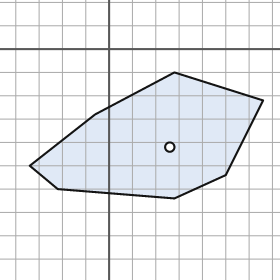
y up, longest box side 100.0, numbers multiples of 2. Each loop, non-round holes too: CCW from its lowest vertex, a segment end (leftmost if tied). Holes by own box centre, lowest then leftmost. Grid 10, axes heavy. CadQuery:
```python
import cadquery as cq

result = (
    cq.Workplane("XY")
    .moveTo(28.0, -64.0)
    .lineTo(50.0, -54.0)
    .lineTo(66.0, -22.0)
    .lineTo(28.0, -10.0)
    .lineTo(-6.0, -28.0)
    .lineTo(-34.0, -50.0)
    .lineTo(-22.0, -60.0)
    .close()
    .moveTo(26.0, -42.0)
    .circle(2.0)
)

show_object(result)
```